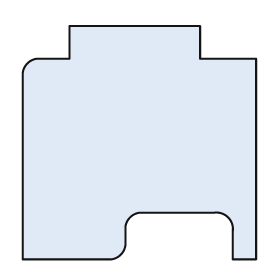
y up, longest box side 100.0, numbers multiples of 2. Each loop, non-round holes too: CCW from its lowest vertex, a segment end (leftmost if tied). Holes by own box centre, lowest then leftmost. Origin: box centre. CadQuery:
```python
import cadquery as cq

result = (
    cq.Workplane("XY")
    .moveTo(-50.0, -50.0)
    .lineTo(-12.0, -50.0)
    .threePointArc((-8.0, -48.0), (-6.0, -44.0))
    .lineTo(-6.0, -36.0)
    .threePointArc((-4.0, -32.0), (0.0, -30.0))
    .lineTo(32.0, -30.0)
    .threePointArc((38.0, -32.0), (40.0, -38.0))
    .lineTo(40.0, -50.0)
    .lineTo(50.0, -50.0)
    .lineTo(50.0, 36.0)
    .lineTo(26.0, 36.0)
    .lineTo(26.0, 50.0)
    .lineTo(-30.0, 50.0)
    .lineTo(-30.0, 36.0)
    .lineTo(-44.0, 36.0)
    .threePointArc((-48.0, 34.0), (-50.0, 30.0))
    .close()
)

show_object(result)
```